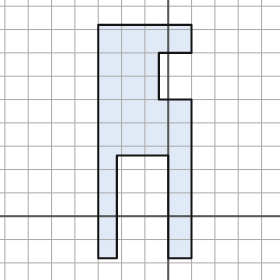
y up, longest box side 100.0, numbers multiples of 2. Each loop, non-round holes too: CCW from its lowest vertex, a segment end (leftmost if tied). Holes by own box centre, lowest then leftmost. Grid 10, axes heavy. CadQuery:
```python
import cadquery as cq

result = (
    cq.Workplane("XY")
    .moveTo(-30.0, -18.0)
    .lineTo(-22.0, -18.0)
    .lineTo(-22.0, 26.0)
    .lineTo(0.0, 26.0)
    .lineTo(0.0, -18.0)
    .lineTo(10.0, -18.0)
    .lineTo(10.0, 50.0)
    .lineTo(-4.0, 50.0)
    .lineTo(-4.0, 70.0)
    .lineTo(10.0, 70.0)
    .lineTo(10.0, 82.0)
    .lineTo(-30.0, 82.0)
    .close()
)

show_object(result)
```